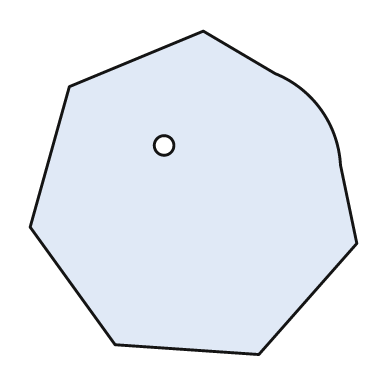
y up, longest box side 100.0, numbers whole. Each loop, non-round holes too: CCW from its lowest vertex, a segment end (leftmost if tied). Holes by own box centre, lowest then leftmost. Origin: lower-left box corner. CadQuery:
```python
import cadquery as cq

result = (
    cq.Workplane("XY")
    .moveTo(70.0, 0.0)
    .lineTo(100.0, 34.0)
    .lineTo(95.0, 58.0)
    .threePointArc((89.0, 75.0), (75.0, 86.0))
    .lineTo(53.0, 99.0)
    .lineTo(12.0, 82.0)
    .lineTo(0.0, 39.0)
    .lineTo(26.0, 3.0)
    .close()
    .moveTo(41.0, 64.0)
    .circle(3.0)
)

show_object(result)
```